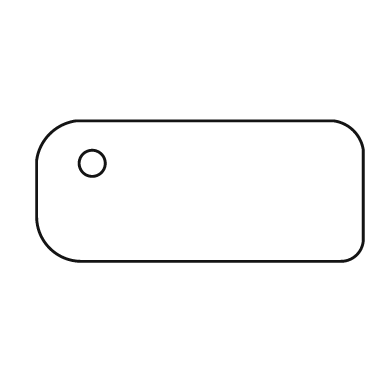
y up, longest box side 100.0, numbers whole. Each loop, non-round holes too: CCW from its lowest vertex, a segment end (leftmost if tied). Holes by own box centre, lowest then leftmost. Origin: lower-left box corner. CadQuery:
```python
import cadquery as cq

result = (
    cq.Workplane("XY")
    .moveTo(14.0, 0.0)
    .lineTo(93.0, 0.0)
    .threePointArc((98.0, 2.0), (100.0, 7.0))
    .lineTo(100.0, 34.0)
    .threePointArc((97.0, 40.0), (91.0, 43.0))
    .lineTo(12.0, 43.0)
    .threePointArc((4.0, 39.0), (0.0, 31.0))
    .lineTo(0.0, 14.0)
    .threePointArc((4.0, 4.0), (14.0, 0.0))
    .close()
    .moveTo(17.0, 30.0)
    .circle(4.0)
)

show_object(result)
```